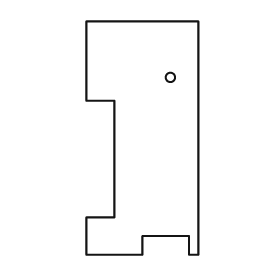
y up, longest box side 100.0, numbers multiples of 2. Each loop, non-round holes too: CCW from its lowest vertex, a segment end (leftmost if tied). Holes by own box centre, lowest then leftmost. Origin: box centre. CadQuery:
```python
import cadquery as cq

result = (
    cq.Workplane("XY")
    .moveTo(-24.0, -50.0)
    .lineTo(0.0, -50.0)
    .lineTo(0.0, -42.0)
    .lineTo(20.0, -42.0)
    .lineTo(20.0, -50.0)
    .lineTo(24.0, -50.0)
    .lineTo(24.0, 50.0)
    .lineTo(-24.0, 50.0)
    .lineTo(-24.0, 16.0)
    .lineTo(-12.0, 16.0)
    .lineTo(-12.0, -34.0)
    .lineTo(-24.0, -34.0)
    .close()
    .moveTo(12.0, 26.0)
    .circle(2.0)
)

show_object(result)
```